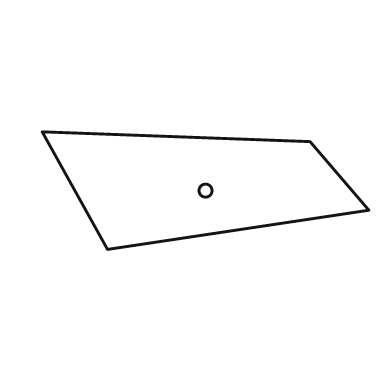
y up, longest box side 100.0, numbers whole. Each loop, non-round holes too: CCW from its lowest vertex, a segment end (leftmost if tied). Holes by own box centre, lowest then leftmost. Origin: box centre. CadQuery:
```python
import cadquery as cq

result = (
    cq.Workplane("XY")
    .moveTo(-30.0, -18.0)
    .lineTo(50.0, -6.0)
    .lineTo(32.0, 15.0)
    .lineTo(-50.0, 18.0)
    .close()
    .moveTo(0.0, 0.0)
    .circle(2.0)
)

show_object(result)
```